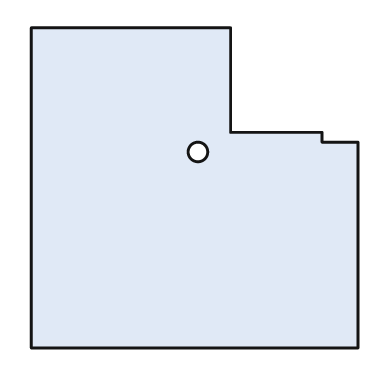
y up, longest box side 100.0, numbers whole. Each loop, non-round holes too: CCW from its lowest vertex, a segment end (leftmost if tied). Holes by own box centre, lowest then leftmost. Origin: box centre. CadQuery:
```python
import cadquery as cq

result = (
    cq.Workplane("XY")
    .moveTo(-50.0, -49.0)
    .lineTo(50.0, -49.0)
    .lineTo(50.0, 14.0)
    .lineTo(39.0, 14.0)
    .lineTo(39.0, 17.0)
    .lineTo(11.0, 17.0)
    .lineTo(11.0, 49.0)
    .lineTo(-50.0, 49.0)
    .close()
    .moveTo(1.0, 11.0)
    .circle(3.0)
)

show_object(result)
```